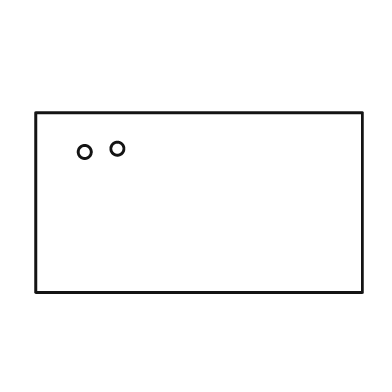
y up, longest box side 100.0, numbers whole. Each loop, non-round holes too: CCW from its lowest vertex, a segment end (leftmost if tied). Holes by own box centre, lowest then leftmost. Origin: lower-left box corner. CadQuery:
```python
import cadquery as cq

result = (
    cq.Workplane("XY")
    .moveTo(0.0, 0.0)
    .lineTo(100.0, 0.0)
    .lineTo(100.0, 55.0)
    .lineTo(0.0, 55.0)
    .close()
    .moveTo(15.0, 43.0)
    .circle(2.0)
    .moveTo(25.0, 44.0)
    .circle(2.0)
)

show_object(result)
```